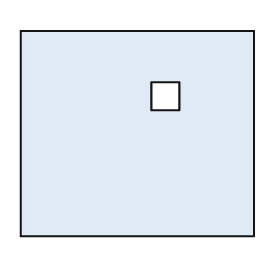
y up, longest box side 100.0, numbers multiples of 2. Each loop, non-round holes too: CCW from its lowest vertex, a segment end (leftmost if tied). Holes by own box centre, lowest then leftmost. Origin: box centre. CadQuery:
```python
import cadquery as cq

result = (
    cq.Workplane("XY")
    .moveTo(-50.0, -44.0)
    .lineTo(50.0, -44.0)
    .lineTo(50.0, 44.0)
    .lineTo(-50.0, 44.0)
    .close()
    .moveTo(6.0, 10.0)
    .lineTo(18.0, 10.0)
    .lineTo(18.0, 22.0)
    .lineTo(6.0, 22.0)
    .close()
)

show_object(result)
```